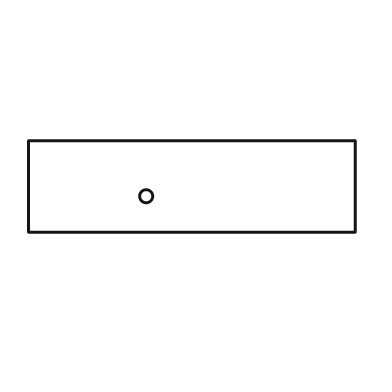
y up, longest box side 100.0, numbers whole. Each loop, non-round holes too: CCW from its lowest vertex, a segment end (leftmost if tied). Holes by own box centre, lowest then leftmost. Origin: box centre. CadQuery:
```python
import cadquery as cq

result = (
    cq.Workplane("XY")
    .moveTo(-50.0, -14.0)
    .lineTo(50.0, -14.0)
    .lineTo(50.0, 14.0)
    .lineTo(-50.0, 14.0)
    .close()
    .moveTo(-14.0, -3.0)
    .circle(2.0)
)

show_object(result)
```